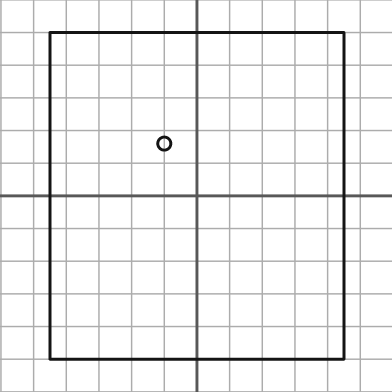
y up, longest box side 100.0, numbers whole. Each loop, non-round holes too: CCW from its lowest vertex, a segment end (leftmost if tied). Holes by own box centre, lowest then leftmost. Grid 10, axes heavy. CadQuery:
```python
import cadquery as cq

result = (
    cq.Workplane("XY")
    .moveTo(-45.0, -50.0)
    .lineTo(45.0, -50.0)
    .lineTo(45.0, 50.0)
    .lineTo(-45.0, 50.0)
    .close()
    .moveTo(-10.0, 16.0)
    .circle(2.0)
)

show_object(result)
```